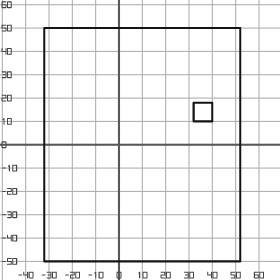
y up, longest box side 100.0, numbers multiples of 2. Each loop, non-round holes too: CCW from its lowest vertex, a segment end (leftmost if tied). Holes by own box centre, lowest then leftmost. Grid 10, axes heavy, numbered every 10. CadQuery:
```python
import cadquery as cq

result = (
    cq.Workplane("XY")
    .moveTo(-32.0, -50.0)
    .lineTo(52.0, -50.0)
    .lineTo(52.0, 50.0)
    .lineTo(-32.0, 50.0)
    .close()
    .moveTo(32.0, 10.0)
    .lineTo(40.0, 10.0)
    .lineTo(40.0, 18.0)
    .lineTo(32.0, 18.0)
    .close()
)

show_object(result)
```